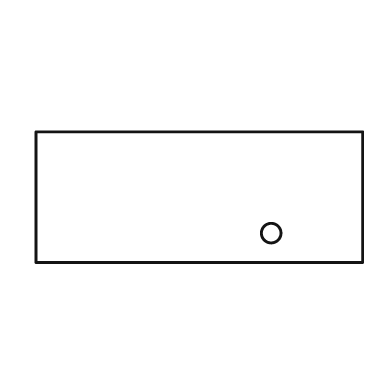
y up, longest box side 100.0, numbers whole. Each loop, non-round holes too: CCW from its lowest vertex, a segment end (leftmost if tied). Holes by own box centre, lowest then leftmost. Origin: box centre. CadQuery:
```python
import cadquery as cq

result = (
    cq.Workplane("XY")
    .moveTo(-50.0, -20.0)
    .lineTo(50.0, -20.0)
    .lineTo(50.0, 20.0)
    .lineTo(-50.0, 20.0)
    .close()
    .moveTo(22.0, -11.0)
    .circle(3.0)
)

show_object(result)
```